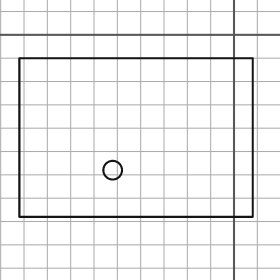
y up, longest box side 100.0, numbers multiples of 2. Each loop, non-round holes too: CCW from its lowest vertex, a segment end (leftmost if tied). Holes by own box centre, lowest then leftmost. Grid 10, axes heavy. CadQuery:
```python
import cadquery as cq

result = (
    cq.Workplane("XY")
    .moveTo(-92.0, -78.0)
    .lineTo(8.0, -78.0)
    .lineTo(8.0, -10.0)
    .lineTo(-92.0, -10.0)
    .close()
    .moveTo(-52.0, -58.0)
    .circle(4.0)
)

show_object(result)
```